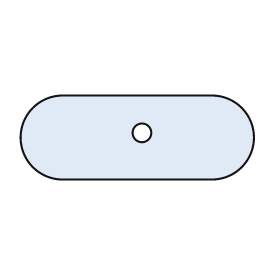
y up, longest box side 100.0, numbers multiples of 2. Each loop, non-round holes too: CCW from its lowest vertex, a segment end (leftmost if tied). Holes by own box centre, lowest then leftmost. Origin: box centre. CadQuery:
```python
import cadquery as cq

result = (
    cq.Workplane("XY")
    .moveTo(-32.0, -18.0)
    .lineTo(32.0, -18.0)
    .threePointArc((50.0, 0.0), (32.0, 18.0))
    .lineTo(-32.0, 18.0)
    .threePointArc((-50.0, 0.0), (-32.0, -18.0))
    .close()
    .moveTo(2.0, 2.0)
    .circle(4.0)
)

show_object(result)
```